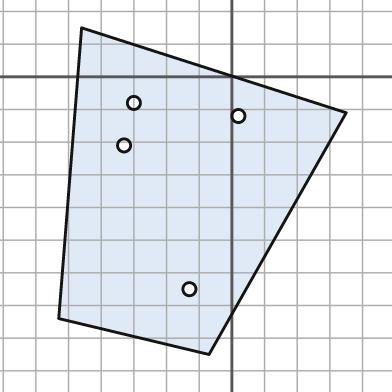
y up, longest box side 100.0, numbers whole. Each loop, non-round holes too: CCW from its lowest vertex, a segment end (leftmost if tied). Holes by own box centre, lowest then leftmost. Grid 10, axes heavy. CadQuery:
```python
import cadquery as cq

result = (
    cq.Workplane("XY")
    .moveTo(-7.0, -85.0)
    .lineTo(35.0, -11.0)
    .lineTo(-46.0, 15.0)
    .lineTo(-53.0, -74.0)
    .close()
    .moveTo(-13.0, -65.0)
    .circle(2.0)
    .moveTo(-33.0, -21.0)
    .circle(2.0)
    .moveTo(2.0, -12.0)
    .circle(2.0)
    .moveTo(-30.0, -8.0)
    .circle(2.0)
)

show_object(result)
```